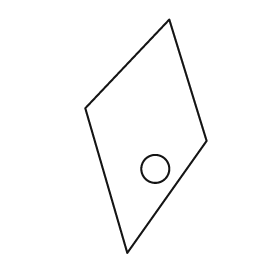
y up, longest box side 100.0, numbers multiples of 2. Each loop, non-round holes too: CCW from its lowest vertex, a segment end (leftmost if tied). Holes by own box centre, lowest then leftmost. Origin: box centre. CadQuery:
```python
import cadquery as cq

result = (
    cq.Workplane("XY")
    .moveTo(-8.0, -50.0)
    .lineTo(26.0, -2.0)
    .lineTo(10.0, 50.0)
    .lineTo(-26.0, 12.0)
    .close()
    .moveTo(4.0, -14.0)
    .circle(6.0)
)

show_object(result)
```